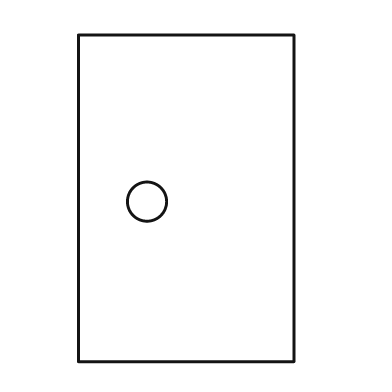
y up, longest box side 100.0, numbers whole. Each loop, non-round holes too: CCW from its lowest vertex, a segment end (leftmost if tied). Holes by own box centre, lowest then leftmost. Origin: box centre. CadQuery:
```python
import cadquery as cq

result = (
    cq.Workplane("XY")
    .moveTo(-33.0, -50.0)
    .lineTo(33.0, -50.0)
    .lineTo(33.0, 50.0)
    .lineTo(-33.0, 50.0)
    .close()
    .moveTo(-12.0, -1.0)
    .circle(6.0)
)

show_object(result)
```